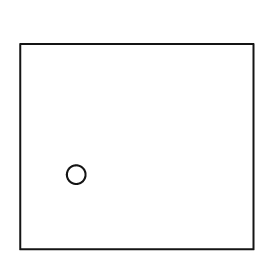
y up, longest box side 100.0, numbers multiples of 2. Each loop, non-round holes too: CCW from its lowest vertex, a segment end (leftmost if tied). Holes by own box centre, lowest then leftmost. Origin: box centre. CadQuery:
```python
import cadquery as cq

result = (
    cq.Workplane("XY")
    .moveTo(-50.0, -44.0)
    .lineTo(50.0, -44.0)
    .lineTo(50.0, 44.0)
    .lineTo(-50.0, 44.0)
    .close()
    .moveTo(-26.0, -12.0)
    .circle(4.0)
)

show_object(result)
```